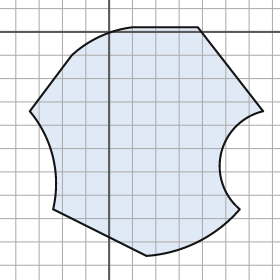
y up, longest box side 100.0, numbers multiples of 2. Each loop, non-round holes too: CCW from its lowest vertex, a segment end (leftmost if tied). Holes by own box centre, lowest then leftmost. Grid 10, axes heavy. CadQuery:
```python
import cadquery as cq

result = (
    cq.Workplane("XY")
    .moveTo(16.0, -96.0)
    .threePointArc((38.0, -90.0), (56.0, -76.0))
    .threePointArc((48.0, -52.0), (66.0, -34.0))
    .lineTo(38.0, 2.0)
    .lineTo(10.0, 2.0)
    .threePointArc((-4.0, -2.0), (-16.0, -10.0))
    .lineTo(-34.0, -34.0)
    .threePointArc((-24.0, -54.0), (-24.0, -76.0))
    .close()
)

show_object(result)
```